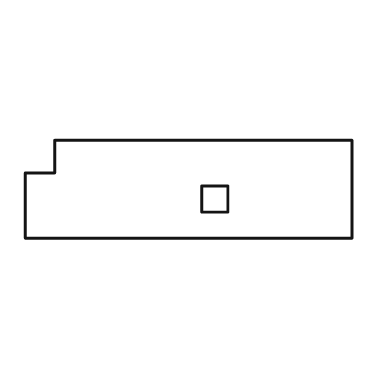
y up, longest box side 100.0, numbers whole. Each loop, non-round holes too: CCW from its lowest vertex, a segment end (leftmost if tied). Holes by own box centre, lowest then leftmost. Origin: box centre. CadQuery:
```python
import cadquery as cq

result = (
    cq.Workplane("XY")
    .moveTo(-50.0, -15.0)
    .lineTo(50.0, -15.0)
    .lineTo(50.0, 15.0)
    .lineTo(-41.0, 15.0)
    .lineTo(-41.0, 5.0)
    .lineTo(-50.0, 5.0)
    .close()
    .moveTo(4.0, -7.0)
    .lineTo(12.0, -7.0)
    .lineTo(12.0, 1.0)
    .lineTo(4.0, 1.0)
    .close()
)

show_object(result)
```